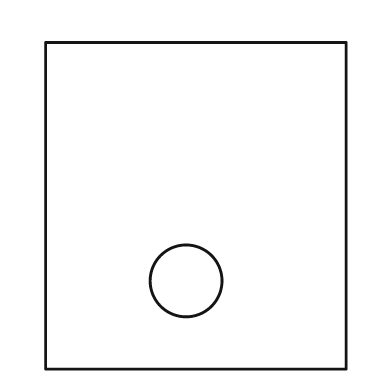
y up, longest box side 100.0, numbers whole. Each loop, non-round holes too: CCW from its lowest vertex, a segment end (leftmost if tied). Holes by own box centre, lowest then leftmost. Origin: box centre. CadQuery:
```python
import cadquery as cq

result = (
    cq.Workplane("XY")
    .moveTo(-46.0, -50.0)
    .lineTo(46.0, -50.0)
    .lineTo(46.0, 50.0)
    .lineTo(-46.0, 50.0)
    .close()
    .moveTo(-3.0, -23.0)
    .circle(11.0)
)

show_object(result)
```